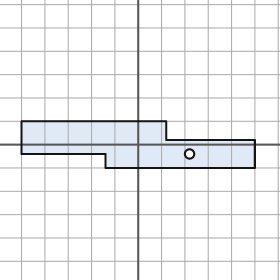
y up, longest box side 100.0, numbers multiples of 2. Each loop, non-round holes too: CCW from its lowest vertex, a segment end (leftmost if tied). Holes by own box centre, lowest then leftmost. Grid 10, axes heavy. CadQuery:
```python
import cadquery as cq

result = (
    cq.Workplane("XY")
    .moveTo(-14.0, -10.0)
    .lineTo(50.0, -10.0)
    .lineTo(50.0, 2.0)
    .lineTo(12.0, 2.0)
    .lineTo(12.0, 10.0)
    .lineTo(-50.0, 10.0)
    .lineTo(-50.0, -4.0)
    .lineTo(-14.0, -4.0)
    .close()
    .moveTo(22.0, -4.0)
    .circle(2.0)
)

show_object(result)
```